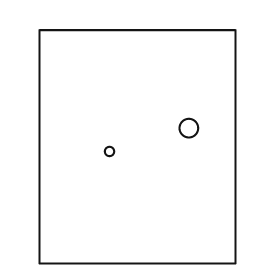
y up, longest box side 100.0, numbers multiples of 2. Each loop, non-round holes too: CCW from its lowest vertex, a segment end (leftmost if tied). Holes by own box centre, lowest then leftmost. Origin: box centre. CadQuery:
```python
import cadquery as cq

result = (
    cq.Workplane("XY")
    .moveTo(-42.0, -50.0)
    .lineTo(42.0, -50.0)
    .lineTo(42.0, 50.0)
    .lineTo(-42.0, 50.0)
    .close()
    .moveTo(-12.0, -2.0)
    .circle(2.0)
    .moveTo(22.0, 8.0)
    .circle(4.0)
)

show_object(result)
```